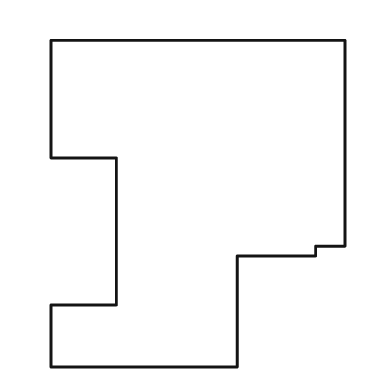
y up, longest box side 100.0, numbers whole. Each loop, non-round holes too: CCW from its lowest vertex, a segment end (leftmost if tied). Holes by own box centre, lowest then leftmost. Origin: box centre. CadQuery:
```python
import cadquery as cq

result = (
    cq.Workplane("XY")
    .moveTo(-45.0, -50.0)
    .lineTo(12.0, -50.0)
    .lineTo(12.0, -16.0)
    .lineTo(36.0, -16.0)
    .lineTo(36.0, -13.0)
    .lineTo(45.0, -13.0)
    .lineTo(45.0, 50.0)
    .lineTo(-45.0, 50.0)
    .lineTo(-45.0, 14.0)
    .lineTo(-25.0, 14.0)
    .lineTo(-25.0, -31.0)
    .lineTo(-45.0, -31.0)
    .close()
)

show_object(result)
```